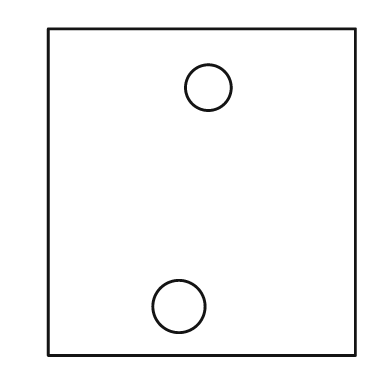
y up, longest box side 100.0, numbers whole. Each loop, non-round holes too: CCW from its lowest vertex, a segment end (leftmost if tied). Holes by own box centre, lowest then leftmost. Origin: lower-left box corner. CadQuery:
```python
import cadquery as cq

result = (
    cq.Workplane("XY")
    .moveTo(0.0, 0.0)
    .lineTo(94.0, 0.0)
    .lineTo(94.0, 100.0)
    .lineTo(0.0, 100.0)
    .close()
    .moveTo(40.0, 15.0)
    .circle(8.0)
    .moveTo(49.0, 82.0)
    .circle(7.0)
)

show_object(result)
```